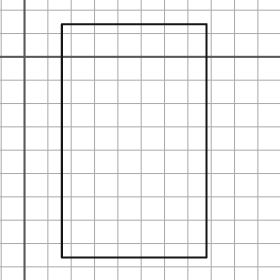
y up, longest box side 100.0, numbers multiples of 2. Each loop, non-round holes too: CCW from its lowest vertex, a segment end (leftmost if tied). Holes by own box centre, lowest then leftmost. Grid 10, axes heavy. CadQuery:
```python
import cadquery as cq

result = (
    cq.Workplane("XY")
    .moveTo(16.0, -86.0)
    .lineTo(78.0, -86.0)
    .lineTo(78.0, 14.0)
    .lineTo(16.0, 14.0)
    .close()
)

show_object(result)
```